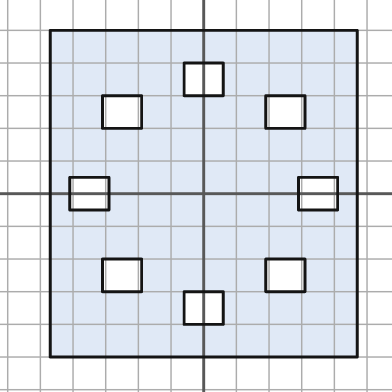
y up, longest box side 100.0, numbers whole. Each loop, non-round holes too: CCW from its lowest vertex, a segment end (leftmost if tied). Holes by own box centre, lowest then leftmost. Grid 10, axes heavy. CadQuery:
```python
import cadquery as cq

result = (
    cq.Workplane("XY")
    .moveTo(-47.0, -50.0)
    .lineTo(47.0, -50.0)
    .lineTo(47.0, 50.0)
    .lineTo(-47.0, 50.0)
    .close()
    .moveTo(-6.0, -40.0)
    .lineTo(6.0, -40.0)
    .lineTo(6.0, -30.0)
    .lineTo(-6.0, -30.0)
    .close()
    .moveTo(-31.0, -30.0)
    .lineTo(-19.0, -30.0)
    .lineTo(-19.0, -20.0)
    .lineTo(-31.0, -20.0)
    .close()
    .moveTo(19.0, -30.0)
    .lineTo(31.0, -30.0)
    .lineTo(31.0, -20.0)
    .lineTo(19.0, -20.0)
    .close()
    .moveTo(-41.0, -5.0)
    .lineTo(-29.0, -5.0)
    .lineTo(-29.0, 5.0)
    .lineTo(-41.0, 5.0)
    .close()
    .moveTo(29.0, -5.0)
    .lineTo(41.0, -5.0)
    .lineTo(41.0, 5.0)
    .lineTo(29.0, 5.0)
    .close()
    .moveTo(-31.0, 20.0)
    .lineTo(-19.0, 20.0)
    .lineTo(-19.0, 30.0)
    .lineTo(-31.0, 30.0)
    .close()
    .moveTo(19.0, 20.0)
    .lineTo(31.0, 20.0)
    .lineTo(31.0, 30.0)
    .lineTo(19.0, 30.0)
    .close()
    .moveTo(-6.0, 30.0)
    .lineTo(6.0, 30.0)
    .lineTo(6.0, 40.0)
    .lineTo(-6.0, 40.0)
    .close()
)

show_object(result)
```